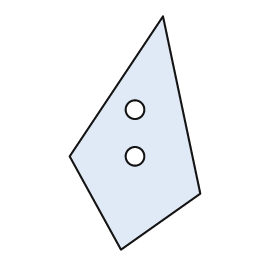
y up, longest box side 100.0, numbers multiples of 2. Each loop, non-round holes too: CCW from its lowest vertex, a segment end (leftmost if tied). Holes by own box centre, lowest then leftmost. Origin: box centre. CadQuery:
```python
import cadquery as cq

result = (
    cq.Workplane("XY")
    .moveTo(-6.0, -50.0)
    .lineTo(28.0, -26.0)
    .lineTo(12.0, 50.0)
    .lineTo(-28.0, -10.0)
    .close()
    .moveTo(0.0, -10.0)
    .circle(4.0)
    .moveTo(0.0, 10.0)
    .circle(4.0)
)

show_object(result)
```